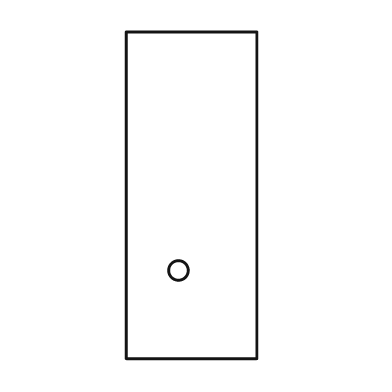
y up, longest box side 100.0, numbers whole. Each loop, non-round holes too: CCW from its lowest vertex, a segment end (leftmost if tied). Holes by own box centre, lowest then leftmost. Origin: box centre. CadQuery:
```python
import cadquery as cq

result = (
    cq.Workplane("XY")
    .moveTo(-20.0, -50.0)
    .lineTo(20.0, -50.0)
    .lineTo(20.0, 50.0)
    .lineTo(-20.0, 50.0)
    .close()
    .moveTo(-4.0, -23.0)
    .circle(3.0)
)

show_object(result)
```